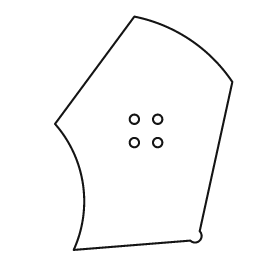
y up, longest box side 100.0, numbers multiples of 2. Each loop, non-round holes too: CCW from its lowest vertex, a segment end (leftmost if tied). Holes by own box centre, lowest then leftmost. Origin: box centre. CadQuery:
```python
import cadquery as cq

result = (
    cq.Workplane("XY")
    .moveTo(-30.0, -50.0)
    .lineTo(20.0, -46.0)
    .threePointArc((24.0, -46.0), (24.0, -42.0))
    .lineTo(38.0, 22.0)
    .threePointArc((20.0, 40.0), (-4.0, 50.0))
    .lineTo(-38.0, 4.0)
    .threePointArc((-26.0, -22.0), (-30.0, -50.0))
    .close()
    .moveTo(-4.0, -4.0)
    .circle(2.0)
    .moveTo(6.0, -4.0)
    .circle(2.0)
    .moveTo(-4.0, 6.0)
    .circle(2.0)
    .moveTo(6.0, 6.0)
    .circle(2.0)
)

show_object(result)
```